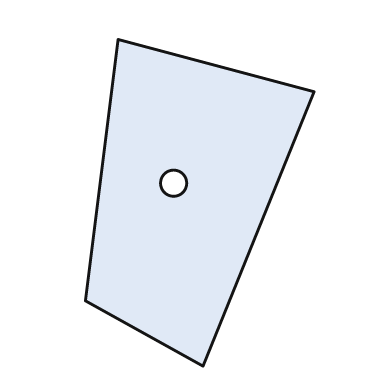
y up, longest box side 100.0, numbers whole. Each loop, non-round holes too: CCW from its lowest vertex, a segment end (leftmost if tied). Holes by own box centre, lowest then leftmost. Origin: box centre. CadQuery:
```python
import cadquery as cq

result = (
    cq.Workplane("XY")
    .moveTo(1.0, -50.0)
    .lineTo(35.0, 34.0)
    .lineTo(-25.0, 50.0)
    .lineTo(-35.0, -30.0)
    .close()
    .moveTo(-8.0, 6.0)
    .circle(4.0)
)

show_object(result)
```